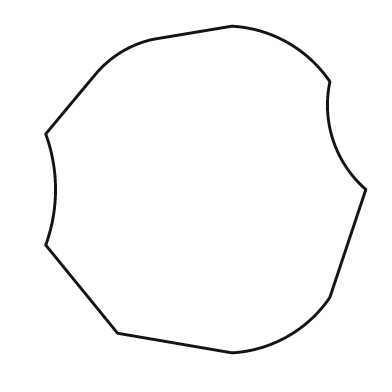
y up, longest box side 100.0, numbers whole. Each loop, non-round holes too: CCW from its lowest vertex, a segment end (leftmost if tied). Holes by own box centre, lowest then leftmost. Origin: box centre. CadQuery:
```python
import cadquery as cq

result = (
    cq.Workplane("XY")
    .moveTo(8.0, -50.0)
    .threePointArc((25.0, -45.0), (38.0, -33.0))
    .lineTo(49.0, 0.0)
    .threePointArc((39.0, 15.0), (38.0, 33.0))
    .threePointArc((25.0, 45.0), (8.0, 50.0))
    .lineTo(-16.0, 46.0)
    .threePointArc((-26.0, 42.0), (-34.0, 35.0))
    .lineTo(-49.0, 17.0)
    .threePointArc((-46.0, 0.0), (-49.0, -17.0))
    .lineTo(-27.0, -44.0)
    .close()
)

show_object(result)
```